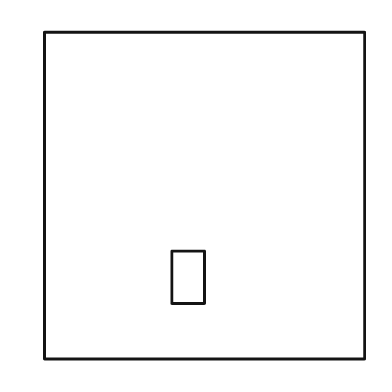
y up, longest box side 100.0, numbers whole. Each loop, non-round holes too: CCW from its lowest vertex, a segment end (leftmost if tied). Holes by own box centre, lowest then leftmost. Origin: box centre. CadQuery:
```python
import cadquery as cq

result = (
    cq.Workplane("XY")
    .moveTo(-49.0, -50.0)
    .lineTo(49.0, -50.0)
    .lineTo(49.0, 50.0)
    .lineTo(-49.0, 50.0)
    .close()
    .moveTo(-10.0, -33.0)
    .lineTo(0.0, -33.0)
    .lineTo(0.0, -17.0)
    .lineTo(-10.0, -17.0)
    .close()
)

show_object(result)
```